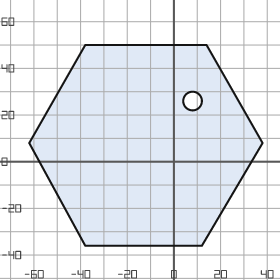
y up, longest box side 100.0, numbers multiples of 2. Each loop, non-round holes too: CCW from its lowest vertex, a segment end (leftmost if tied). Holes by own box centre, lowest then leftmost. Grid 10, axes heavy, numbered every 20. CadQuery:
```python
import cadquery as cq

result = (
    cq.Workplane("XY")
    .moveTo(-38.0, -36.0)
    .lineTo(12.0, -36.0)
    .lineTo(38.0, 8.0)
    .lineTo(14.0, 50.0)
    .lineTo(-38.0, 50.0)
    .lineTo(-62.0, 8.0)
    .close()
    .moveTo(8.0, 26.0)
    .circle(4.0)
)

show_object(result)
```